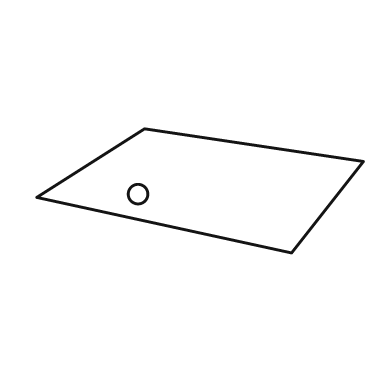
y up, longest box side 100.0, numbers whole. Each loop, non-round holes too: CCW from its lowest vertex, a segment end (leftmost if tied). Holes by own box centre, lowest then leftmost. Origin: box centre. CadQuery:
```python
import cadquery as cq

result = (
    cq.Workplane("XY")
    .moveTo(28.0, -19.0)
    .lineTo(50.0, 9.0)
    .lineTo(-17.0, 19.0)
    .lineTo(-50.0, -2.0)
    .close()
    .moveTo(-19.0, -1.0)
    .circle(3.0)
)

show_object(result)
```